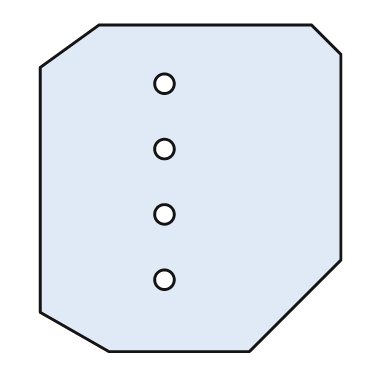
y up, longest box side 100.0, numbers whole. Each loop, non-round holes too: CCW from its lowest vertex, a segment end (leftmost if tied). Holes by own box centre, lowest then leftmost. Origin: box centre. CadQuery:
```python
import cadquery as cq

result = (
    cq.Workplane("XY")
    .moveTo(-25.0, -50.0)
    .lineTo(18.0, -50.0)
    .lineTo(46.0, -22.0)
    .lineTo(46.0, 41.0)
    .lineTo(37.0, 50.0)
    .lineTo(-28.0, 50.0)
    .lineTo(-46.0, 37.0)
    .lineTo(-46.0, -38.0)
    .close()
    .moveTo(-8.0, -28.0)
    .circle(3.0)
    .moveTo(-8.0, -8.0)
    .circle(3.0)
    .moveTo(-8.0, 12.0)
    .circle(3.0)
    .moveTo(-8.0, 32.0)
    .circle(3.0)
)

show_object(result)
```